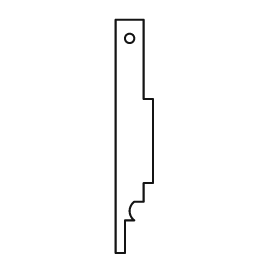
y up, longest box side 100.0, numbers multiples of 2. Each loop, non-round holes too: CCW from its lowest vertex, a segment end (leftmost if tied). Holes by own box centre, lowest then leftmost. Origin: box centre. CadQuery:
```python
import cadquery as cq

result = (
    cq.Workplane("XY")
    .moveTo(-8.0, -50.0)
    .lineTo(-4.0, -50.0)
    .lineTo(-4.0, -36.0)
    .lineTo(0.0, -36.0)
    .threePointArc((-2.0, -32.0), (0.0, -28.0))
    .lineTo(4.0, -28.0)
    .lineTo(4.0, -20.0)
    .lineTo(8.0, -20.0)
    .lineTo(8.0, 16.0)
    .lineTo(4.0, 16.0)
    .lineTo(4.0, 50.0)
    .lineTo(-8.0, 50.0)
    .close()
    .moveTo(-2.0, 42.0)
    .circle(2.0)
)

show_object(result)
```